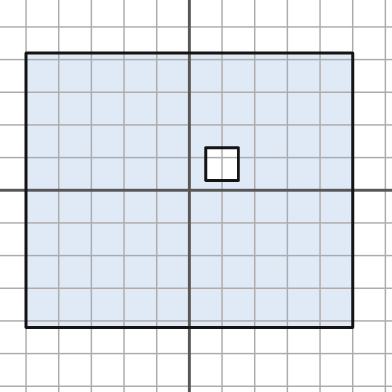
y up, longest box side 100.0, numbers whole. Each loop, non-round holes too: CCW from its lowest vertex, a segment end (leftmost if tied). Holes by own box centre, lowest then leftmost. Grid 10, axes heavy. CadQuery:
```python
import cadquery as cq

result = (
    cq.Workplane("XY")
    .moveTo(-50.0, -42.0)
    .lineTo(50.0, -42.0)
    .lineTo(50.0, 42.0)
    .lineTo(-50.0, 42.0)
    .close()
    .moveTo(5.0, 3.0)
    .lineTo(15.0, 3.0)
    .lineTo(15.0, 13.0)
    .lineTo(5.0, 13.0)
    .close()
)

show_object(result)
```